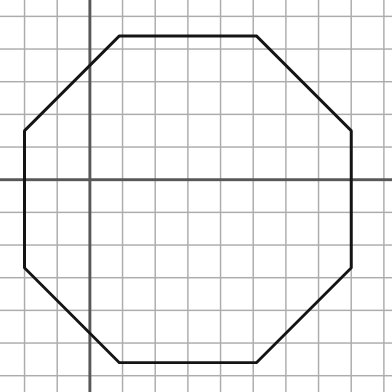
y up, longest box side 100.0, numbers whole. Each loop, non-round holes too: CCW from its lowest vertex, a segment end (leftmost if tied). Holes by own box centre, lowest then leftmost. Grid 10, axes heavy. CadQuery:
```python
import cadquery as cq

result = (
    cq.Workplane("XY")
    .moveTo(9.0, -56.0)
    .lineTo(51.0, -56.0)
    .lineTo(80.0, -27.0)
    .lineTo(80.0, 15.0)
    .lineTo(51.0, 44.0)
    .lineTo(9.0, 44.0)
    .lineTo(-20.0, 15.0)
    .lineTo(-20.0, -27.0)
    .close()
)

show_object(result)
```